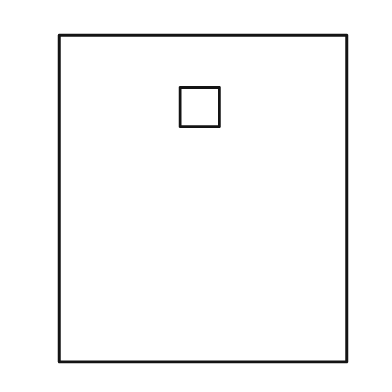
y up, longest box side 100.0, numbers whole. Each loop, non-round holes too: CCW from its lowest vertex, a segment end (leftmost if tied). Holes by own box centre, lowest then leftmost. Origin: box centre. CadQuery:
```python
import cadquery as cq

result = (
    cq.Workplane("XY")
    .moveTo(-44.0, -50.0)
    .lineTo(44.0, -50.0)
    .lineTo(44.0, 50.0)
    .lineTo(-44.0, 50.0)
    .close()
    .moveTo(-7.0, 22.0)
    .lineTo(5.0, 22.0)
    .lineTo(5.0, 34.0)
    .lineTo(-7.0, 34.0)
    .close()
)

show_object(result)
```